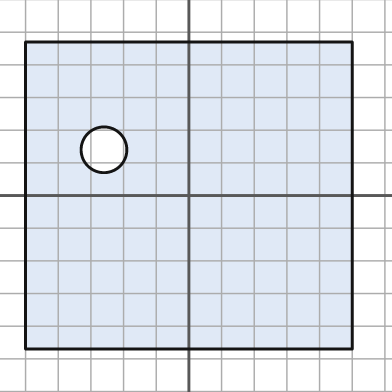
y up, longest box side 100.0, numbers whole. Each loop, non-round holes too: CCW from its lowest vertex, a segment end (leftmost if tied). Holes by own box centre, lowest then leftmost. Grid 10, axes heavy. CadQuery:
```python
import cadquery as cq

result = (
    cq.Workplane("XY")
    .moveTo(-50.0, -47.0)
    .lineTo(50.0, -47.0)
    .lineTo(50.0, 47.0)
    .lineTo(-50.0, 47.0)
    .close()
    .moveTo(-26.0, 14.0)
    .circle(7.0)
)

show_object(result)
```